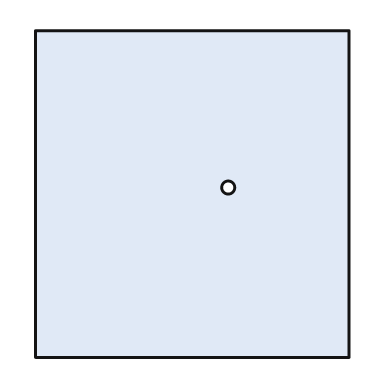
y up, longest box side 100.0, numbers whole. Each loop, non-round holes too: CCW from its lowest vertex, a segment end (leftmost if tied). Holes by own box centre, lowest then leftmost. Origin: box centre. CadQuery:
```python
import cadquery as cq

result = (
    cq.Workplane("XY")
    .moveTo(-48.0, -50.0)
    .lineTo(48.0, -50.0)
    .lineTo(48.0, 50.0)
    .lineTo(-48.0, 50.0)
    .close()
    .moveTo(11.0, 2.0)
    .circle(2.0)
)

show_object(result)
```